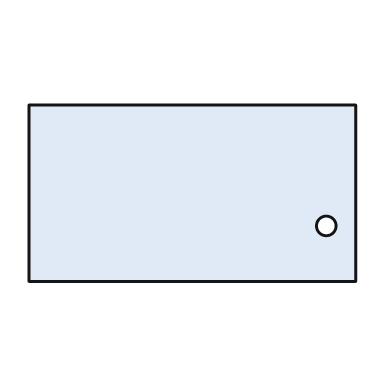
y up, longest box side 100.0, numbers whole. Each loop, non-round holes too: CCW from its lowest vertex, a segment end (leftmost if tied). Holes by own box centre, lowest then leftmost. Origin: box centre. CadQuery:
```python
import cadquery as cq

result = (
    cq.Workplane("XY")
    .moveTo(-50.0, -27.0)
    .lineTo(50.0, -27.0)
    .lineTo(50.0, 27.0)
    .lineTo(-50.0, 27.0)
    .close()
    .moveTo(41.0, -10.0)
    .circle(3.0)
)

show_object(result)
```